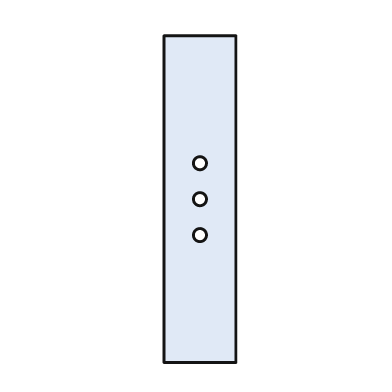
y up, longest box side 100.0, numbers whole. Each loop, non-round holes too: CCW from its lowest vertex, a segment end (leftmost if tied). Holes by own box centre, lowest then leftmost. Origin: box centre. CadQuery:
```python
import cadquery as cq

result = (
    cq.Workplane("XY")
    .moveTo(-11.0, -50.0)
    .lineTo(11.0, -50.0)
    .lineTo(11.0, 50.0)
    .lineTo(-11.0, 50.0)
    .close()
    .moveTo(0.0, -11.0)
    .circle(2.0)
    .moveTo(0.0, 0.0)
    .circle(2.0)
    .moveTo(0.0, 11.0)
    .circle(2.0)
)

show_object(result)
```